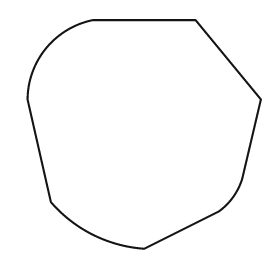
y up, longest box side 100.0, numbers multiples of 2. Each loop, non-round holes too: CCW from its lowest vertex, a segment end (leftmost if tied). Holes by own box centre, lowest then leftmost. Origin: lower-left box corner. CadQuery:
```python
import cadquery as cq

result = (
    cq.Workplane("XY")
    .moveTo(50.0, 0.0)
    .lineTo(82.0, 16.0)
    .threePointArc((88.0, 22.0), (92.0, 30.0))
    .lineTo(100.0, 64.0)
    .lineTo(72.0, 98.0)
    .lineTo(28.0, 98.0)
    .threePointArc((8.0, 86.0), (0.0, 64.0))
    .lineTo(10.0, 20.0)
    .threePointArc((28.0, 6.0), (50.0, 0.0))
    .close()
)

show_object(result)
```